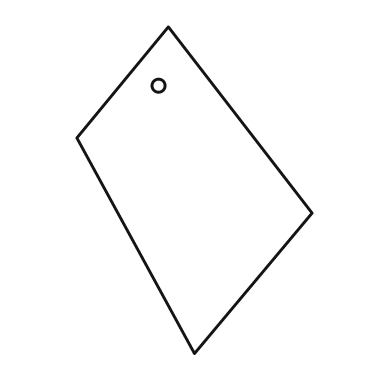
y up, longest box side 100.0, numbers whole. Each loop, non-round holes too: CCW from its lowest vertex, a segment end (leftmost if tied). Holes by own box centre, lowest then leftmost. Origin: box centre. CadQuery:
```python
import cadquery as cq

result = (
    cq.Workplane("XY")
    .moveTo(0.0, -50.0)
    .lineTo(36.0, -7.0)
    .lineTo(-8.0, 50.0)
    .lineTo(-36.0, 16.0)
    .close()
    .moveTo(-11.0, 32.0)
    .circle(2.0)
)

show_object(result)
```